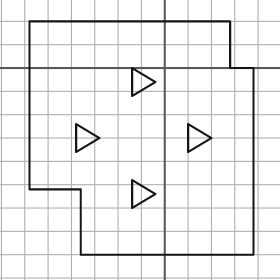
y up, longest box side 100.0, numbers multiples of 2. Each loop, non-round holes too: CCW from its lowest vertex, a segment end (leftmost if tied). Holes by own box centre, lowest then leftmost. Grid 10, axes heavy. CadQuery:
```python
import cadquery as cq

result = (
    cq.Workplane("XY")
    .moveTo(-36.0, -80.0)
    .lineTo(38.0, -80.0)
    .lineTo(38.0, 0.0)
    .lineTo(28.0, 0.0)
    .lineTo(28.0, 20.0)
    .lineTo(-58.0, 20.0)
    .lineTo(-58.0, -52.0)
    .lineTo(-36.0, -52.0)
    .close()
    .moveTo(-14.0, -60.0)
    .lineTo(-4.0, -54.0)
    .lineTo(-14.0, -48.0)
    .close()
    .moveTo(-38.0, -36.0)
    .lineTo(-28.0, -30.0)
    .lineTo(-38.0, -24.0)
    .close()
    .moveTo(10.0, -36.0)
    .lineTo(20.0, -30.0)
    .lineTo(10.0, -24.0)
    .close()
    .moveTo(-14.0, -12.0)
    .lineTo(-4.0, -6.0)
    .lineTo(-14.0, 0.0)
    .close()
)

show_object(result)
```